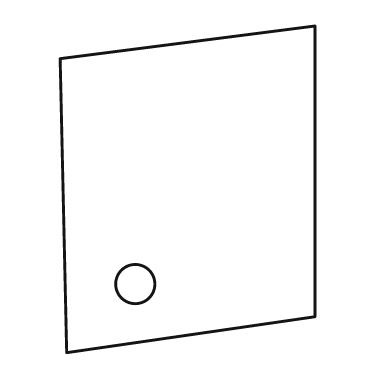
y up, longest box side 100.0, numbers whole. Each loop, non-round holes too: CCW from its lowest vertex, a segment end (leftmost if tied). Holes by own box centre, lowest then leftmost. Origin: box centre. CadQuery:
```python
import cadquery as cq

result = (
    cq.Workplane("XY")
    .moveTo(-37.0, -50.0)
    .lineTo(39.0, -39.0)
    .lineTo(39.0, 50.0)
    .lineTo(-39.0, 40.0)
    .close()
    .moveTo(-16.0, -29.0)
    .circle(6.0)
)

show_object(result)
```